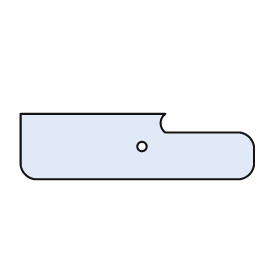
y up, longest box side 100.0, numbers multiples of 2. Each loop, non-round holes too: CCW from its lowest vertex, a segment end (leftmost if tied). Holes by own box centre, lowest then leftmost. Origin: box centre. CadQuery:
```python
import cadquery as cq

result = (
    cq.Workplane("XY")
    .moveTo(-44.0, -14.0)
    .lineTo(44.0, -14.0)
    .threePointArc((48.0, -12.0), (50.0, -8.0))
    .lineTo(50.0, 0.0)
    .threePointArc((48.0, 4.0), (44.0, 6.0))
    .lineTo(12.0, 6.0)
    .threePointArc((10.0, 10.0), (12.0, 14.0))
    .lineTo(-50.0, 14.0)
    .lineTo(-50.0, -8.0)
    .threePointArc((-48.0, -12.0), (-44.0, -14.0))
    .close()
    .moveTo(2.0, 0.0)
    .circle(2.0)
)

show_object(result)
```